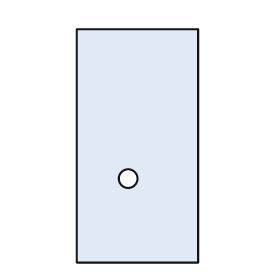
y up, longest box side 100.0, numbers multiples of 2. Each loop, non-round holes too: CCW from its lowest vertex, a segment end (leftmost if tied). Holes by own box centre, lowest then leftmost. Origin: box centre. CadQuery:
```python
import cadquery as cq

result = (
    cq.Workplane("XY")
    .moveTo(-26.0, -50.0)
    .lineTo(26.0, -50.0)
    .lineTo(26.0, 50.0)
    .lineTo(-26.0, 50.0)
    .close()
    .moveTo(-4.0, -14.0)
    .circle(4.0)
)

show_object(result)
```